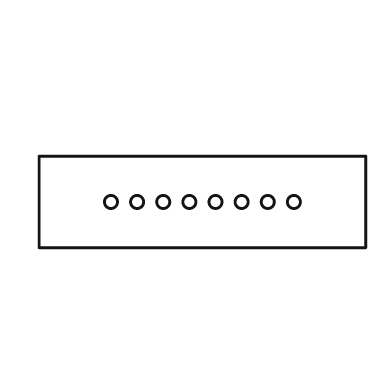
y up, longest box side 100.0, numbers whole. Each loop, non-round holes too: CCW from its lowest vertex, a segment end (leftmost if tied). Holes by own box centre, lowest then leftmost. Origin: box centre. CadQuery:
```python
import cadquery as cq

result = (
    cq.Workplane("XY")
    .moveTo(-50.0, -14.0)
    .lineTo(50.0, -14.0)
    .lineTo(50.0, 14.0)
    .lineTo(-50.0, 14.0)
    .close()
    .moveTo(-28.0, 0.0)
    .circle(2.0)
    .moveTo(-20.0, 0.0)
    .circle(2.0)
    .moveTo(-12.0, 0.0)
    .circle(2.0)
    .moveTo(-4.0, 0.0)
    .circle(2.0)
    .moveTo(4.0, 0.0)
    .circle(2.0)
    .moveTo(12.0, 0.0)
    .circle(2.0)
    .moveTo(20.0, 0.0)
    .circle(2.0)
    .moveTo(28.0, 0.0)
    .circle(2.0)
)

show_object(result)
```